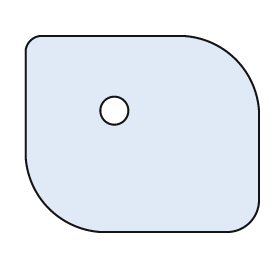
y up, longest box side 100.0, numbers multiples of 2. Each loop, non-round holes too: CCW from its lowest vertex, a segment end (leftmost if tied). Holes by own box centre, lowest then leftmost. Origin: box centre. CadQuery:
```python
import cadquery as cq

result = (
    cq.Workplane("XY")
    .moveTo(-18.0, -42.0)
    .lineTo(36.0, -42.0)
    .threePointArc((46.0, -38.0), (50.0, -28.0))
    .lineTo(50.0, 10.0)
    .threePointArc((40.0, 32.0), (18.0, 42.0))
    .lineTo(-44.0, 42.0)
    .threePointArc((-48.0, 40.0), (-50.0, 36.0))
    .lineTo(-50.0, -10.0)
    .threePointArc((-40.0, -32.0), (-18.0, -42.0))
    .close()
    .moveTo(-12.0, 10.0)
    .circle(6.0)
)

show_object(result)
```